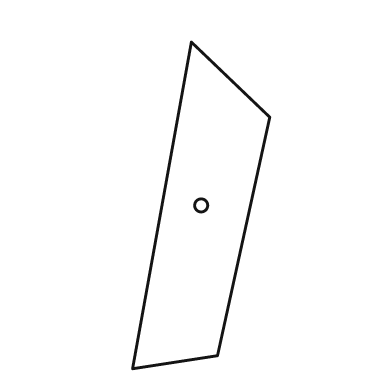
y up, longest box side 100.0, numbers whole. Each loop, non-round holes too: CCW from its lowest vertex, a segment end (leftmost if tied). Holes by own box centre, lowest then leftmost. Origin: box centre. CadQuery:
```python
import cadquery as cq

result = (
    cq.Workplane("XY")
    .moveTo(-21.0, -50.0)
    .lineTo(5.0, -46.0)
    .lineTo(21.0, 27.0)
    .lineTo(-3.0, 50.0)
    .close()
    .moveTo(0.0, 0.0)
    .circle(2.0)
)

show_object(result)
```